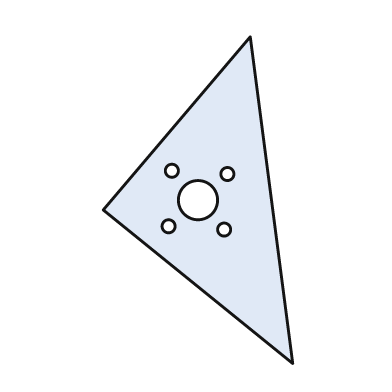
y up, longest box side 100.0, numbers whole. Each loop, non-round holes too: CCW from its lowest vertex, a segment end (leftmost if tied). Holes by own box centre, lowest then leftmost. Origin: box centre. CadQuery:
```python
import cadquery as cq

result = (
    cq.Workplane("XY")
    .moveTo(29.0, -50.0)
    .lineTo(16.0, 50.0)
    .lineTo(-29.0, -3.0)
    .close()
    .moveTo(8.0, -9.0)
    .circle(2.0)
    .moveTo(-9.0, -8.0)
    .circle(2.0)
    .moveTo(0.0, 0.0)
    .circle(6.0)
    .moveTo(9.0, 8.0)
    .circle(2.0)
    .moveTo(-8.0, 9.0)
    .circle(2.0)
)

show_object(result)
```